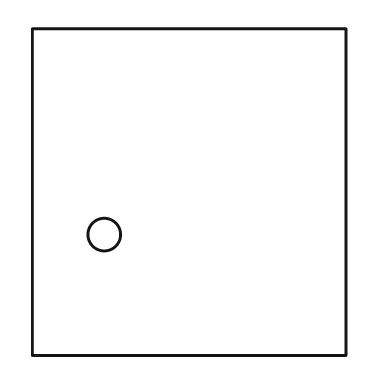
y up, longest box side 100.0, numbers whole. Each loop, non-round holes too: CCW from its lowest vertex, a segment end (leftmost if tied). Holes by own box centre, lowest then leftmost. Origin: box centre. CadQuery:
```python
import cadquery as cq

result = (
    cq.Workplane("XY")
    .moveTo(-48.0, -50.0)
    .lineTo(48.0, -50.0)
    .lineTo(48.0, 50.0)
    .lineTo(-48.0, 50.0)
    .close()
    .moveTo(-26.0, -13.0)
    .circle(5.0)
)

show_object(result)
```